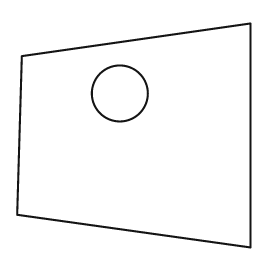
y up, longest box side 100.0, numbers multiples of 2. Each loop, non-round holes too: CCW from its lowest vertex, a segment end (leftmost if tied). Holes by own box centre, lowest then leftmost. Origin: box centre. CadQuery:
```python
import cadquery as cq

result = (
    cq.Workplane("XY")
    .moveTo(50.0, -48.0)
    .lineTo(50.0, 48.0)
    .lineTo(-48.0, 34.0)
    .lineTo(-50.0, -34.0)
    .close()
    .moveTo(-6.0, 18.0)
    .circle(12.0)
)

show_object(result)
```